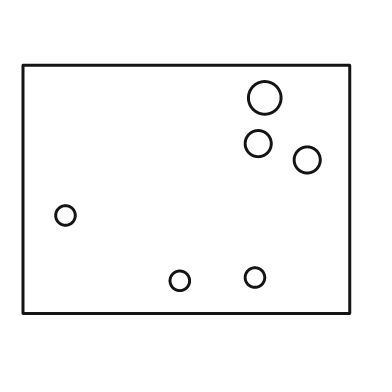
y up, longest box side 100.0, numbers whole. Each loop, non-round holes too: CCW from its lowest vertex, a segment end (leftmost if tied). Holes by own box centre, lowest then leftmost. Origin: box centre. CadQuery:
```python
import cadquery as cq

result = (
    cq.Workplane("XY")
    .moveTo(-50.0, -38.0)
    .lineTo(50.0, -38.0)
    .lineTo(50.0, 38.0)
    .lineTo(-50.0, 38.0)
    .close()
    .moveTo(-2.0, -28.0)
    .circle(3.0)
    .moveTo(21.0, -27.0)
    .circle(3.0)
    .moveTo(-37.0, -8.0)
    .circle(3.0)
    .moveTo(37.0, 9.0)
    .circle(4.0)
    .moveTo(22.0, 14.0)
    .circle(4.0)
    .moveTo(24.0, 28.0)
    .circle(5.0)
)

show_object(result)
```